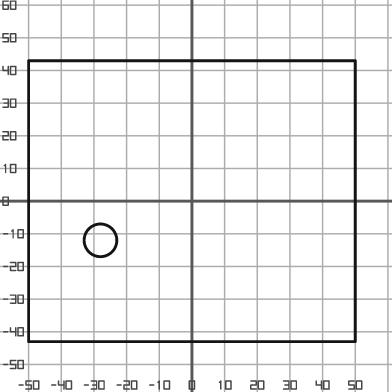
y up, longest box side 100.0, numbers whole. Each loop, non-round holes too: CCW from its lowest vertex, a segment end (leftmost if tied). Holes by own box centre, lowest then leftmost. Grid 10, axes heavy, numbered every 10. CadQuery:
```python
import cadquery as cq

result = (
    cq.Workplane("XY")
    .moveTo(-50.0, -43.0)
    .lineTo(50.0, -43.0)
    .lineTo(50.0, 43.0)
    .lineTo(-50.0, 43.0)
    .close()
    .moveTo(-28.0, -12.0)
    .circle(5.0)
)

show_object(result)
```